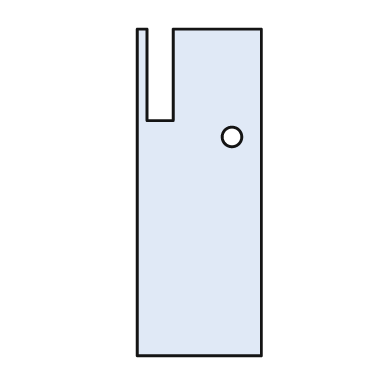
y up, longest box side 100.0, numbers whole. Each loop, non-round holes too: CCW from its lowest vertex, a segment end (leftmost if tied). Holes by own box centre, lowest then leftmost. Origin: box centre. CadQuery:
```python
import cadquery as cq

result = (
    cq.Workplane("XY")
    .moveTo(-19.0, -50.0)
    .lineTo(19.0, -50.0)
    .lineTo(19.0, 50.0)
    .lineTo(-8.0, 50.0)
    .lineTo(-8.0, 22.0)
    .lineTo(-16.0, 22.0)
    .lineTo(-16.0, 50.0)
    .lineTo(-19.0, 50.0)
    .close()
    .moveTo(10.0, 17.0)
    .circle(3.0)
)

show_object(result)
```